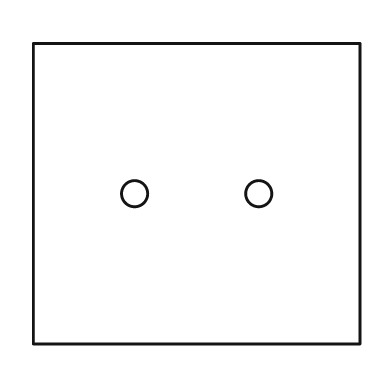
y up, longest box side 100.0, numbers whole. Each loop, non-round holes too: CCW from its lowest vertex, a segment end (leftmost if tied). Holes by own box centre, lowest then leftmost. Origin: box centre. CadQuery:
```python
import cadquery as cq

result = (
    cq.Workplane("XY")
    .moveTo(-50.0, -46.0)
    .lineTo(50.0, -46.0)
    .lineTo(50.0, 46.0)
    .lineTo(-50.0, 46.0)
    .close()
    .moveTo(-19.0, 0.0)
    .circle(4.0)
    .moveTo(19.0, 0.0)
    .circle(4.0)
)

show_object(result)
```